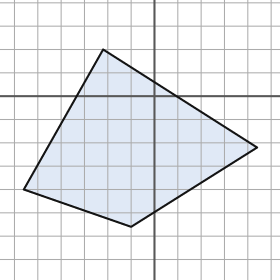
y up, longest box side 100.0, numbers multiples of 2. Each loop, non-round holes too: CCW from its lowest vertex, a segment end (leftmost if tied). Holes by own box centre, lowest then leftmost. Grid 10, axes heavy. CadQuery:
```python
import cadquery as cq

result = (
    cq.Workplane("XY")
    .moveTo(-10.0, -56.0)
    .lineTo(44.0, -22.0)
    .lineTo(-22.0, 20.0)
    .lineTo(-56.0, -40.0)
    .close()
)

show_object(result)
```